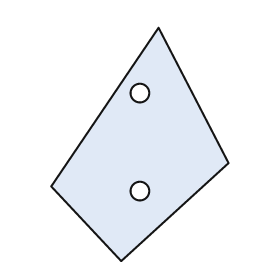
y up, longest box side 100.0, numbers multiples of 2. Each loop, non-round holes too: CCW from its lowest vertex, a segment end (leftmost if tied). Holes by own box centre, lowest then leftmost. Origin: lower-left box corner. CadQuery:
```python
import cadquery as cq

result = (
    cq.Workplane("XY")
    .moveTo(30.0, 0.0)
    .lineTo(76.0, 42.0)
    .lineTo(46.0, 100.0)
    .lineTo(0.0, 32.0)
    .close()
    .moveTo(38.0, 30.0)
    .circle(4.0)
    .moveTo(38.0, 72.0)
    .circle(4.0)
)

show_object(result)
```